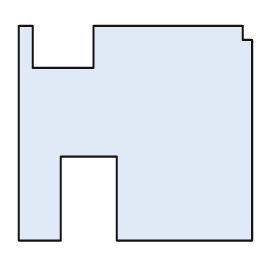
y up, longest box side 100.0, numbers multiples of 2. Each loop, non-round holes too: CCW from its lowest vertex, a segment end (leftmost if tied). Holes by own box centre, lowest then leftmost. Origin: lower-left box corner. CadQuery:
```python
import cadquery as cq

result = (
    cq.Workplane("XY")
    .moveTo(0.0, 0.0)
    .lineTo(18.0, 0.0)
    .lineTo(18.0, 36.0)
    .lineTo(42.0, 36.0)
    .lineTo(42.0, 0.0)
    .lineTo(100.0, 0.0)
    .lineTo(100.0, 86.0)
    .lineTo(96.0, 86.0)
    .lineTo(96.0, 92.0)
    .lineTo(32.0, 92.0)
    .lineTo(32.0, 74.0)
    .lineTo(6.0, 74.0)
    .lineTo(6.0, 92.0)
    .lineTo(0.0, 92.0)
    .close()
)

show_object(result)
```